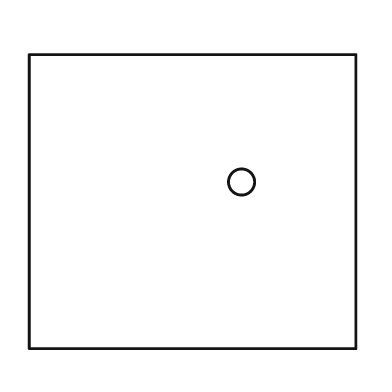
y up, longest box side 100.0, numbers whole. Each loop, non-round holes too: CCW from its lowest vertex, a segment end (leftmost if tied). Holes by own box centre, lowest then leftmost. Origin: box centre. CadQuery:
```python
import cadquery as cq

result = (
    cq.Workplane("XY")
    .moveTo(-50.0, -45.0)
    .lineTo(50.0, -45.0)
    .lineTo(50.0, 45.0)
    .lineTo(-50.0, 45.0)
    .close()
    .moveTo(15.0, 6.0)
    .circle(4.0)
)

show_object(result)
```